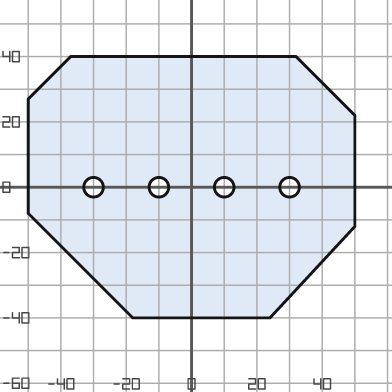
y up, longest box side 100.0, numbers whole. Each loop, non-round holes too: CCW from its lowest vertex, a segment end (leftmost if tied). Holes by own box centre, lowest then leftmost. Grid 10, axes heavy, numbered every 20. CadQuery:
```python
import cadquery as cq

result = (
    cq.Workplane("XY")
    .moveTo(-18.0, -40.0)
    .lineTo(24.0, -40.0)
    .lineTo(50.0, -12.0)
    .lineTo(50.0, 22.0)
    .lineTo(32.0, 40.0)
    .lineTo(-37.0, 40.0)
    .lineTo(-50.0, 27.0)
    .lineTo(-50.0, -8.0)
    .close()
    .moveTo(-30.0, 0.0)
    .circle(3.0)
    .moveTo(-10.0, 0.0)
    .circle(3.0)
    .moveTo(10.0, 0.0)
    .circle(3.0)
    .moveTo(30.0, 0.0)
    .circle(3.0)
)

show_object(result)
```